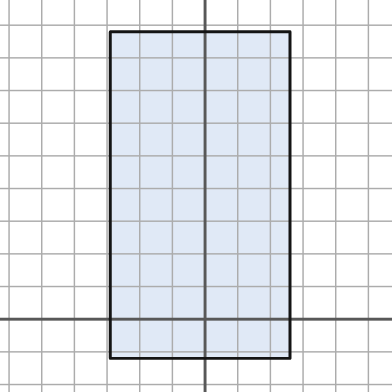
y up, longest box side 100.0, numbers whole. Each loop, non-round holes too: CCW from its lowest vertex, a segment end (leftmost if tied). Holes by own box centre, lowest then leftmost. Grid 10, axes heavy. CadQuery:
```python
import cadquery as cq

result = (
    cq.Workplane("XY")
    .moveTo(-29.0, -12.0)
    .lineTo(26.0, -12.0)
    .lineTo(26.0, 88.0)
    .lineTo(-29.0, 88.0)
    .close()
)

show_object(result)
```